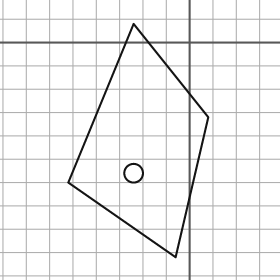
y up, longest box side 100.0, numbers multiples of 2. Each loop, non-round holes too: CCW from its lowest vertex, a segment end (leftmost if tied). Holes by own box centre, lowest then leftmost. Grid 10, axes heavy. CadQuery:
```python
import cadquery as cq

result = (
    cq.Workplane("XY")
    .moveTo(-6.0, -92.0)
    .lineTo(8.0, -32.0)
    .lineTo(-24.0, 8.0)
    .lineTo(-52.0, -60.0)
    .close()
    .moveTo(-24.0, -56.0)
    .circle(4.0)
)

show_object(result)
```